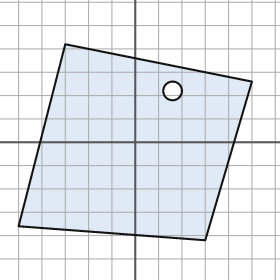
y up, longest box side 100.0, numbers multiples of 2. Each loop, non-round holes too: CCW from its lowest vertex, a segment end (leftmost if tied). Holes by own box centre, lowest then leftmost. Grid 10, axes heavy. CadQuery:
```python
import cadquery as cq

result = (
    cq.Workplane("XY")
    .moveTo(30.0, -42.0)
    .lineTo(50.0, 26.0)
    .lineTo(-30.0, 42.0)
    .lineTo(-50.0, -36.0)
    .close()
    .moveTo(16.0, 22.0)
    .circle(4.0)
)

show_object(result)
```